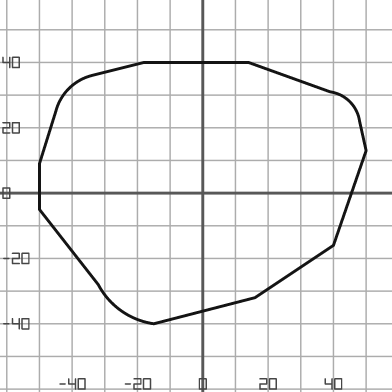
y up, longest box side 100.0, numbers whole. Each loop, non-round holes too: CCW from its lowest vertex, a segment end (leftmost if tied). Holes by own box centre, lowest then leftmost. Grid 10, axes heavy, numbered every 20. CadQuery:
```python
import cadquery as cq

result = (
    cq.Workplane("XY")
    .moveTo(-15.0, -40.0)
    .lineTo(16.0, -32.0)
    .lineTo(40.0, -16.0)
    .lineTo(50.0, 13.0)
    .lineTo(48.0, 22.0)
    .threePointArc((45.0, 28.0), (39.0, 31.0))
    .lineTo(14.0, 40.0)
    .lineTo(-18.0, 40.0)
    .lineTo(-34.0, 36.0)
    .threePointArc((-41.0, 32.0), (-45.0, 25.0))
    .lineTo(-50.0, 9.0)
    .lineTo(-50.0, -5.0)
    .lineTo(-32.0, -28.0)
    .threePointArc((-25.0, -36.0), (-15.0, -40.0))
    .close()
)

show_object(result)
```